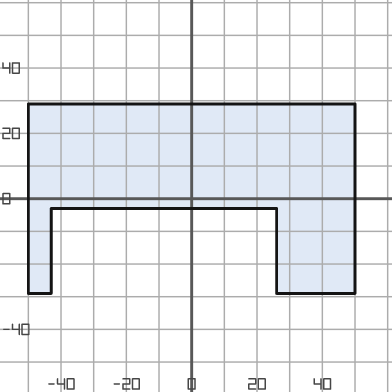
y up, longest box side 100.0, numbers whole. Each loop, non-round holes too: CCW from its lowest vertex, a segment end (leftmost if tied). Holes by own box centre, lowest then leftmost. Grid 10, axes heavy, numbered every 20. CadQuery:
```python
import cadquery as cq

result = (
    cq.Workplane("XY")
    .moveTo(-50.0, -29.0)
    .lineTo(-43.0, -29.0)
    .lineTo(-43.0, -3.0)
    .lineTo(26.0, -3.0)
    .lineTo(26.0, -29.0)
    .lineTo(50.0, -29.0)
    .lineTo(50.0, 29.0)
    .lineTo(-50.0, 29.0)
    .close()
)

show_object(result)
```